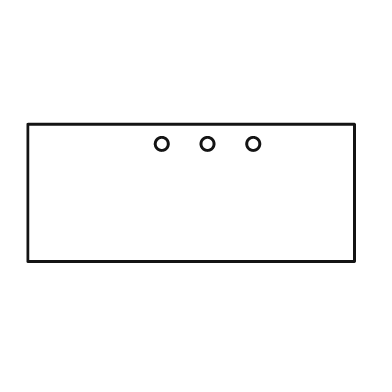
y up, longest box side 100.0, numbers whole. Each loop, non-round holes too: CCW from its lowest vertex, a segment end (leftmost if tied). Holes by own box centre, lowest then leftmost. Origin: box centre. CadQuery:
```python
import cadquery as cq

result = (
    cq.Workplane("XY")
    .moveTo(-50.0, -21.0)
    .lineTo(50.0, -21.0)
    .lineTo(50.0, 21.0)
    .lineTo(-50.0, 21.0)
    .close()
    .moveTo(-9.0, 15.0)
    .circle(2.0)
    .moveTo(5.0, 15.0)
    .circle(2.0)
    .moveTo(19.0, 15.0)
    .circle(2.0)
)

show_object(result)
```